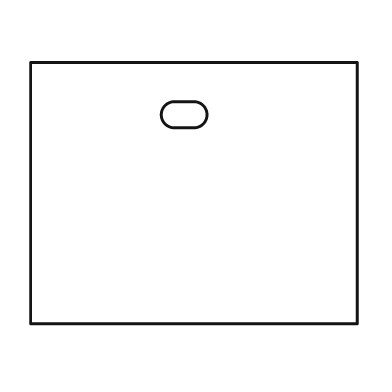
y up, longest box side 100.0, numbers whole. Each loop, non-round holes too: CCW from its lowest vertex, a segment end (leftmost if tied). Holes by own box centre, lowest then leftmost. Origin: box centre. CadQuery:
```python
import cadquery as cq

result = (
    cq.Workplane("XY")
    .moveTo(-50.0, -40.0)
    .lineTo(50.0, -40.0)
    .lineTo(50.0, 40.0)
    .lineTo(-50.0, 40.0)
    .close()
    .moveTo(-6.0, 20.0)
    .lineTo(0.0, 20.0)
    .threePointArc((4.0, 24.0), (0.0, 28.0))
    .lineTo(-6.0, 28.0)
    .threePointArc((-10.0, 24.0), (-6.0, 20.0))
    .close()
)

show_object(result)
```